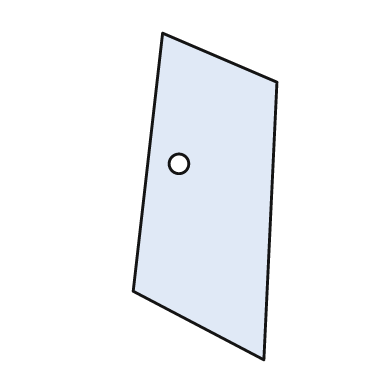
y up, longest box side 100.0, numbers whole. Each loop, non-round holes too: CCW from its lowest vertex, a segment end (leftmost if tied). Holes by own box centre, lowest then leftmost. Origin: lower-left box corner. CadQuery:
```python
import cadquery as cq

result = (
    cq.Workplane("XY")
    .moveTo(40.0, 0.0)
    .lineTo(44.0, 85.0)
    .lineTo(9.0, 100.0)
    .lineTo(0.0, 21.0)
    .close()
    .moveTo(14.0, 60.0)
    .circle(3.0)
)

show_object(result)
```